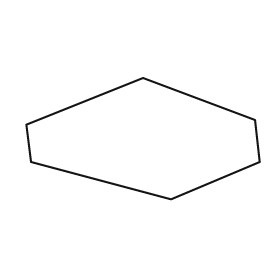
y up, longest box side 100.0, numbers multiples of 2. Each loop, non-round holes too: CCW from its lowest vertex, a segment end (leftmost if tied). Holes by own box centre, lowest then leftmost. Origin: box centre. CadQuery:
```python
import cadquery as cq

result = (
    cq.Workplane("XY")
    .moveTo(12.0, -26.0)
    .lineTo(50.0, -10.0)
    .lineTo(48.0, 8.0)
    .lineTo(0.0, 26.0)
    .lineTo(-50.0, 6.0)
    .lineTo(-48.0, -10.0)
    .close()
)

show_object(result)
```